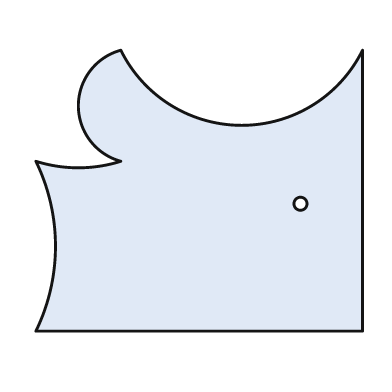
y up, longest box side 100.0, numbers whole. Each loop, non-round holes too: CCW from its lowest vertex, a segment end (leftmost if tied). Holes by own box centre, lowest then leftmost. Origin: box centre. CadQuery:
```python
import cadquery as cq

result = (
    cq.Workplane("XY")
    .moveTo(-50.0, -43.0)
    .lineTo(50.0, -43.0)
    .lineTo(50.0, 43.0)
    .threePointArc((13.0, 20.0), (-24.0, 43.0))
    .threePointArc((-37.0, 26.0), (-24.0, 9.0))
    .threePointArc((-37.0, 7.0), (-50.0, 9.0))
    .threePointArc((-44.0, -17.0), (-50.0, -43.0))
    .close()
    .moveTo(31.0, -4.0)
    .circle(2.0)
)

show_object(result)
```